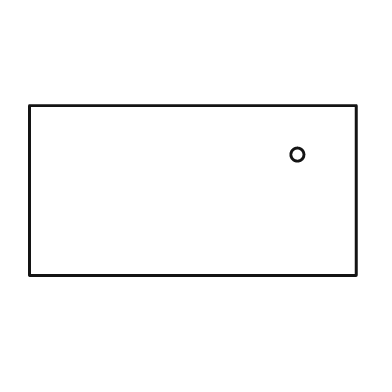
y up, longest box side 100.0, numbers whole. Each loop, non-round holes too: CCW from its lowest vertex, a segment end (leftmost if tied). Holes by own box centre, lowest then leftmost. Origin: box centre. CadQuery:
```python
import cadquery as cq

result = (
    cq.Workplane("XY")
    .moveTo(-50.0, -26.0)
    .lineTo(50.0, -26.0)
    .lineTo(50.0, 26.0)
    .lineTo(-50.0, 26.0)
    .close()
    .moveTo(32.0, 11.0)
    .circle(2.0)
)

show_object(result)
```